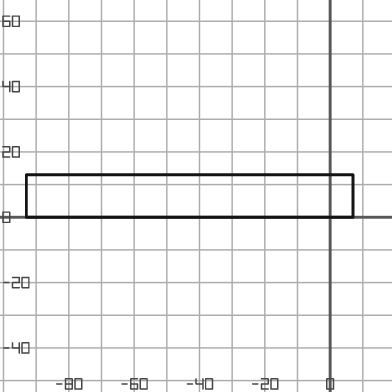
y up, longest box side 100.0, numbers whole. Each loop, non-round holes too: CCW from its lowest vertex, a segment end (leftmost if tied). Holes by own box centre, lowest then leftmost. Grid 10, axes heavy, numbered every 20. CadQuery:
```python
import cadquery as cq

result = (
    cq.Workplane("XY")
    .moveTo(-93.0, 0.0)
    .lineTo(7.0, 0.0)
    .lineTo(7.0, 13.0)
    .lineTo(-93.0, 13.0)
    .close()
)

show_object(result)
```